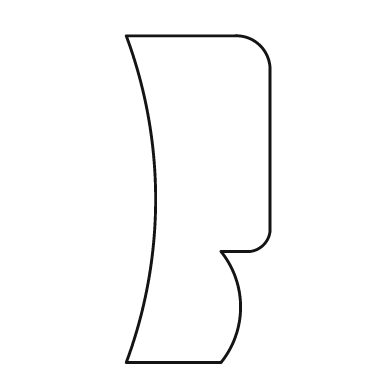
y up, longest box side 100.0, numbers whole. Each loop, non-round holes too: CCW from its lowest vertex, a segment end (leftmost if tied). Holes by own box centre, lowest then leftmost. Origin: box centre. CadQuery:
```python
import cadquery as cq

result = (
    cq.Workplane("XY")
    .moveTo(-22.0, -50.0)
    .lineTo(7.0, -50.0)
    .threePointArc((13.0, -33.0), (7.0, -16.0))
    .lineTo(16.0, -16.0)
    .threePointArc((20.0, -14.0), (22.0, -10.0))
    .lineTo(22.0, 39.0)
    .threePointArc((19.0, 47.0), (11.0, 50.0))
    .lineTo(-22.0, 50.0)
    .threePointArc((-13.0, 0.0), (-22.0, -50.0))
    .close()
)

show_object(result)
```